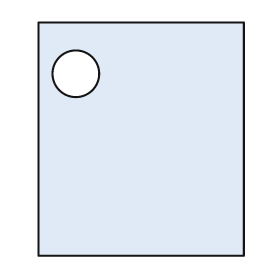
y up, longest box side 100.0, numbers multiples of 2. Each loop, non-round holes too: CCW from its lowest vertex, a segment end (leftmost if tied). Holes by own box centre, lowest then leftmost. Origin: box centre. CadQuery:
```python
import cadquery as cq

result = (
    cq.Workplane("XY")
    .moveTo(-44.0, -50.0)
    .lineTo(44.0, -50.0)
    .lineTo(44.0, 50.0)
    .lineTo(-44.0, 50.0)
    .close()
    .moveTo(-28.0, 28.0)
    .circle(10.0)
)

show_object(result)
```